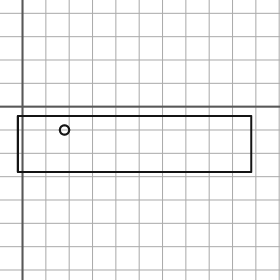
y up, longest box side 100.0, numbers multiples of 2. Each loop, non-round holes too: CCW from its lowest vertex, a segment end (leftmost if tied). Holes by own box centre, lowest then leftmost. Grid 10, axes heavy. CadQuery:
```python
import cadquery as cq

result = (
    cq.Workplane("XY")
    .moveTo(-2.0, -28.0)
    .lineTo(98.0, -28.0)
    .lineTo(98.0, -4.0)
    .lineTo(-2.0, -4.0)
    .close()
    .moveTo(18.0, -10.0)
    .circle(2.0)
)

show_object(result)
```